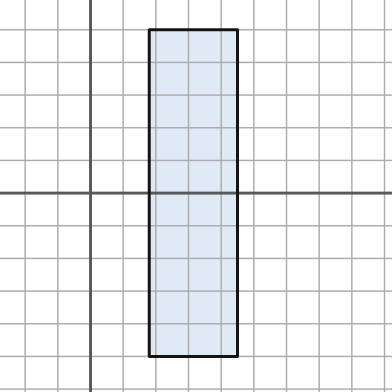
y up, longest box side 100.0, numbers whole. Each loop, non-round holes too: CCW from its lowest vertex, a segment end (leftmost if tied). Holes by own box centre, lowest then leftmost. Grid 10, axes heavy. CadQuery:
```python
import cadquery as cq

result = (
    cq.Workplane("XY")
    .moveTo(18.0, -50.0)
    .lineTo(45.0, -50.0)
    .lineTo(45.0, 50.0)
    .lineTo(18.0, 50.0)
    .close()
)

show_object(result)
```